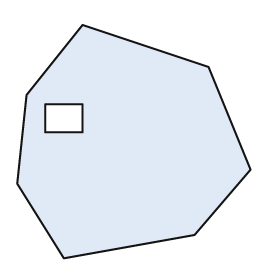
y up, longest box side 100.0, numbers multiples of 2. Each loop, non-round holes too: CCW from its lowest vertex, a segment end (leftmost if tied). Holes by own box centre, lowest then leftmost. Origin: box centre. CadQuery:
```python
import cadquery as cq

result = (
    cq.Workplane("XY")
    .moveTo(-30.0, -50.0)
    .lineTo(26.0, -40.0)
    .lineTo(50.0, -12.0)
    .lineTo(32.0, 32.0)
    .lineTo(-22.0, 50.0)
    .lineTo(-46.0, 20.0)
    .lineTo(-50.0, -18.0)
    .close()
    .moveTo(-38.0, 4.0)
    .lineTo(-22.0, 4.0)
    .lineTo(-22.0, 16.0)
    .lineTo(-38.0, 16.0)
    .close()
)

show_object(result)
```